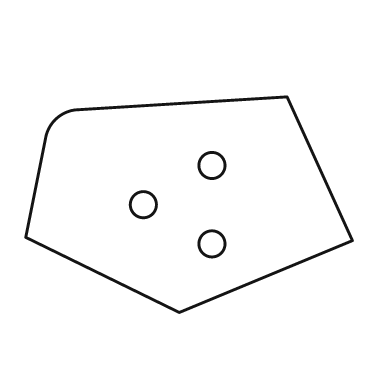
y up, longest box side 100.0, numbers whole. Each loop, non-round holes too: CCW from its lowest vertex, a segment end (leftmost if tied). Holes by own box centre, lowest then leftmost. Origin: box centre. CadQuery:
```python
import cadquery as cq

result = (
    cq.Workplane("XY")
    .moveTo(-3.0, -33.0)
    .lineTo(50.0, -11.0)
    .lineTo(30.0, 33.0)
    .lineTo(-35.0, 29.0)
    .threePointArc((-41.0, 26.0), (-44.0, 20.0))
    .lineTo(-50.0, -10.0)
    .close()
    .moveTo(7.0, -12.0)
    .circle(4.0)
    .moveTo(-14.0, 0.0)
    .circle(4.0)
    .moveTo(7.0, 12.0)
    .circle(4.0)
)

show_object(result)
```